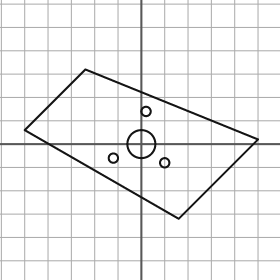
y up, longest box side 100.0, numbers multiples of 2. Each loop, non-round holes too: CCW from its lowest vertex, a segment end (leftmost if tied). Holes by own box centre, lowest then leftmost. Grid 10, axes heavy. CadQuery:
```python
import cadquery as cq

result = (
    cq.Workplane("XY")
    .moveTo(16.0, -32.0)
    .lineTo(50.0, 2.0)
    .lineTo(-24.0, 32.0)
    .lineTo(-50.0, 6.0)
    .close()
    .moveTo(10.0, -8.0)
    .circle(2.0)
    .moveTo(-12.0, -6.0)
    .circle(2.0)
    .moveTo(0.0, 0.0)
    .circle(6.0)
    .moveTo(2.0, 14.0)
    .circle(2.0)
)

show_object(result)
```